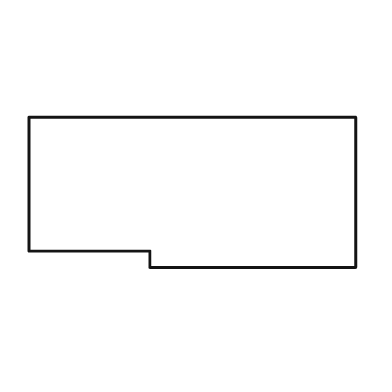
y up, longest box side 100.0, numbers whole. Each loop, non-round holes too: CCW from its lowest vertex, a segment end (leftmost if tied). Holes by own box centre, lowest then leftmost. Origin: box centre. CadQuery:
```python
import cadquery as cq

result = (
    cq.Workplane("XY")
    .moveTo(-13.0, -23.0)
    .lineTo(50.0, -23.0)
    .lineTo(50.0, 23.0)
    .lineTo(-50.0, 23.0)
    .lineTo(-50.0, -18.0)
    .lineTo(-13.0, -18.0)
    .close()
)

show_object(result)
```